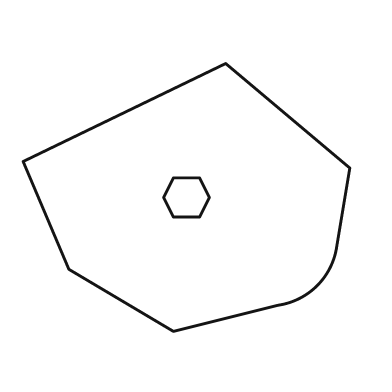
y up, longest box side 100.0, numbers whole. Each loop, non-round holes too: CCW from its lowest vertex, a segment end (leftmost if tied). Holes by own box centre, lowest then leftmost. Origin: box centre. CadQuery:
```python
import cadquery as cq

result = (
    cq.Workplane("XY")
    .moveTo(-4.0, -41.0)
    .lineTo(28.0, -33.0)
    .threePointArc((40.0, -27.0), (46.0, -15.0))
    .lineTo(50.0, 9.0)
    .lineTo(12.0, 41.0)
    .lineTo(-50.0, 11.0)
    .lineTo(-36.0, -22.0)
    .close()
    .moveTo(-4.0, -6.0)
    .lineTo(4.0, -6.0)
    .lineTo(7.0, 0.0)
    .lineTo(4.0, 6.0)
    .lineTo(-4.0, 6.0)
    .lineTo(-7.0, 0.0)
    .close()
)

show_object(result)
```